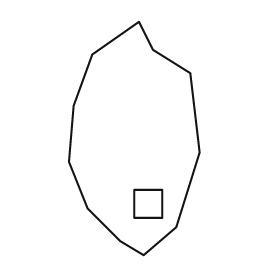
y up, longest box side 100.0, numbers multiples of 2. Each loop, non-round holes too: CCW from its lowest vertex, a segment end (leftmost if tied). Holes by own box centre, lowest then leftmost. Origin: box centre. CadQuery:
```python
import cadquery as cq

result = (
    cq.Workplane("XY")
    .moveTo(4.0, -50.0)
    .lineTo(18.0, -38.0)
    .lineTo(28.0, -6.0)
    .lineTo(24.0, 28.0)
    .lineTo(8.0, 38.0)
    .lineTo(2.0, 50.0)
    .lineTo(-18.0, 36.0)
    .lineTo(-26.0, 14.0)
    .lineTo(-28.0, -10.0)
    .lineTo(-20.0, -30.0)
    .lineTo(-6.0, -44.0)
    .close()
    .moveTo(0.0, -34.0)
    .lineTo(12.0, -34.0)
    .lineTo(12.0, -22.0)
    .lineTo(0.0, -22.0)
    .close()
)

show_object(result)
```